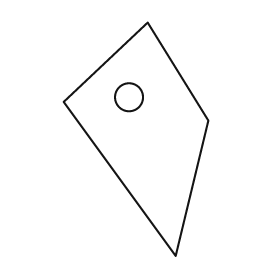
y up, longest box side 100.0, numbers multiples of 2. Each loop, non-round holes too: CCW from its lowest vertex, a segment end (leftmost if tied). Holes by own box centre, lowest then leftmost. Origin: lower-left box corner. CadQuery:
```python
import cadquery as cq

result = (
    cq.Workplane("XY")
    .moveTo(48.0, 0.0)
    .lineTo(62.0, 58.0)
    .lineTo(36.0, 100.0)
    .lineTo(0.0, 66.0)
    .close()
    .moveTo(28.0, 68.0)
    .circle(6.0)
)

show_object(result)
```